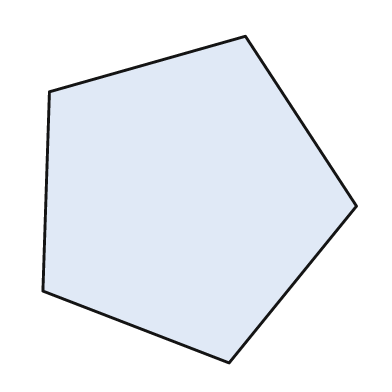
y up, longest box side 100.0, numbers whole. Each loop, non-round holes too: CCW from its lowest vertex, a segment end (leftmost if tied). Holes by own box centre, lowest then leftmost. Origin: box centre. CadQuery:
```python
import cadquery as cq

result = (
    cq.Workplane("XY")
    .moveTo(9.0, -50.0)
    .lineTo(48.0, -2.0)
    .lineTo(14.0, 50.0)
    .lineTo(-46.0, 33.0)
    .lineTo(-48.0, -28.0)
    .close()
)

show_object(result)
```